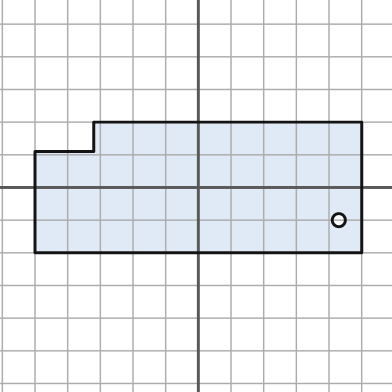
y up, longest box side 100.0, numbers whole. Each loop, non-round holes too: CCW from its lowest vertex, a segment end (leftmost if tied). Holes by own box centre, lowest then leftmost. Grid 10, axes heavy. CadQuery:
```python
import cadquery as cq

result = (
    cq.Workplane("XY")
    .moveTo(-50.0, -20.0)
    .lineTo(50.0, -20.0)
    .lineTo(50.0, 20.0)
    .lineTo(-32.0, 20.0)
    .lineTo(-32.0, 11.0)
    .lineTo(-50.0, 11.0)
    .close()
    .moveTo(43.0, -10.0)
    .circle(2.0)
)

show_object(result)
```